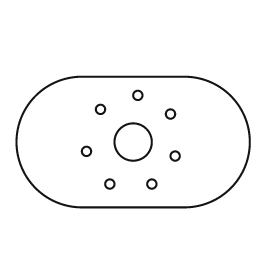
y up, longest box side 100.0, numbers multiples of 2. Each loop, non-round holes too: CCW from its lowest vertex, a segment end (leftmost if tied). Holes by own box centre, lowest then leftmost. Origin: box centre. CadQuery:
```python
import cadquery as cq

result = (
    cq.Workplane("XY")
    .moveTo(-22.0, -28.0)
    .lineTo(22.0, -28.0)
    .threePointArc((50.0, 0.0), (22.0, 28.0))
    .lineTo(-22.0, 28.0)
    .threePointArc((-50.0, 0.0), (-22.0, -28.0))
    .close()
    .moveTo(-10.0, -18.0)
    .circle(2.0)
    .moveTo(8.0, -18.0)
    .circle(2.0)
    .moveTo(18.0, -6.0)
    .circle(2.0)
    .moveTo(-20.0, -4.0)
    .circle(2.0)
    .moveTo(0.0, 0.0)
    .circle(8.0)
    .moveTo(16.0, 12.0)
    .circle(2.0)
    .moveTo(-14.0, 14.0)
    .circle(2.0)
    .moveTo(2.0, 20.0)
    .circle(2.0)
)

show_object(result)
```